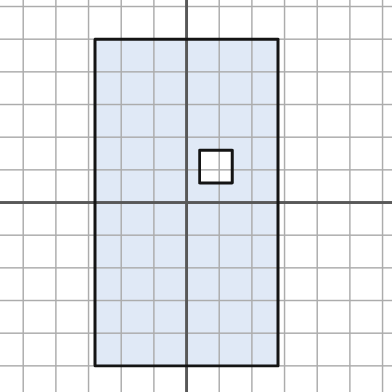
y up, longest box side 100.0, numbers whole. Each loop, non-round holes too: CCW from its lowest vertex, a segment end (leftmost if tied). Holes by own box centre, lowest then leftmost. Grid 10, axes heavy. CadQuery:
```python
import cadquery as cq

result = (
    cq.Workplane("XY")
    .moveTo(-28.0, -50.0)
    .lineTo(28.0, -50.0)
    .lineTo(28.0, 50.0)
    .lineTo(-28.0, 50.0)
    .close()
    .moveTo(4.0, 6.0)
    .lineTo(14.0, 6.0)
    .lineTo(14.0, 16.0)
    .lineTo(4.0, 16.0)
    .close()
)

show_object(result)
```